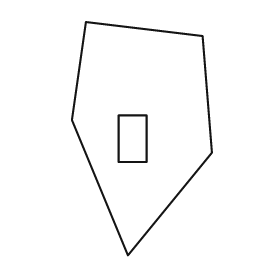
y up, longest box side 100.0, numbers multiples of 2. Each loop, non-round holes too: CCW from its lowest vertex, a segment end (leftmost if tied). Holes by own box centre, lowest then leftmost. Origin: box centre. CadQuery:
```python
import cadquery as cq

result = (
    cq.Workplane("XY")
    .moveTo(-6.0, -50.0)
    .lineTo(30.0, -6.0)
    .lineTo(26.0, 44.0)
    .lineTo(-24.0, 50.0)
    .lineTo(-30.0, 8.0)
    .close()
    .moveTo(-10.0, -10.0)
    .lineTo(2.0, -10.0)
    .lineTo(2.0, 10.0)
    .lineTo(-10.0, 10.0)
    .close()
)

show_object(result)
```